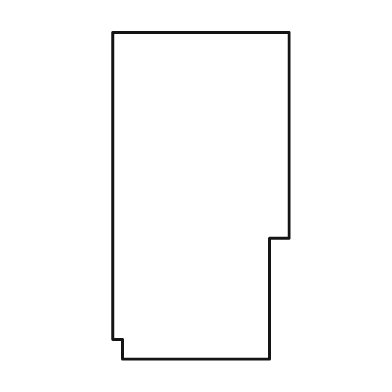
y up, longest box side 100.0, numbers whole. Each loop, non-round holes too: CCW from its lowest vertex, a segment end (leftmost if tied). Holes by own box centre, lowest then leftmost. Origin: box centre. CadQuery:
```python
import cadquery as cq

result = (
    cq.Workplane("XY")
    .moveTo(-24.0, -50.0)
    .lineTo(21.0, -50.0)
    .lineTo(21.0, -13.0)
    .lineTo(27.0, -13.0)
    .lineTo(27.0, 50.0)
    .lineTo(-27.0, 50.0)
    .lineTo(-27.0, -44.0)
    .lineTo(-24.0, -44.0)
    .close()
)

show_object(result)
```